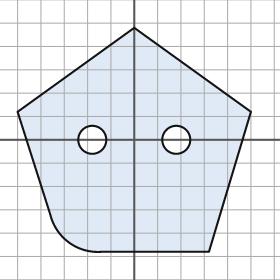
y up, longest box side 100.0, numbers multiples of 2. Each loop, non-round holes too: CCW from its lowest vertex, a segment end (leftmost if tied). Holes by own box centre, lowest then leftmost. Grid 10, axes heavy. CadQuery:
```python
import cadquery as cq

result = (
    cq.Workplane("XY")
    .moveTo(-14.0, -48.0)
    .lineTo(32.0, -48.0)
    .lineTo(50.0, 12.0)
    .lineTo(0.0, 48.0)
    .lineTo(-50.0, 12.0)
    .lineTo(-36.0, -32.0)
    .threePointArc((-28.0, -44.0), (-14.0, -48.0))
    .close()
    .moveTo(-18.0, 0.0)
    .circle(6.0)
    .moveTo(18.0, 0.0)
    .circle(6.0)
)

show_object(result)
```